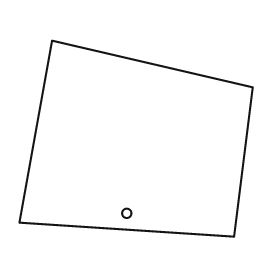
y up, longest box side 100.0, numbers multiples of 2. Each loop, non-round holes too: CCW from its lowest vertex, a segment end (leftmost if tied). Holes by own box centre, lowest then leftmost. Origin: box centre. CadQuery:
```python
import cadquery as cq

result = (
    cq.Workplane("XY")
    .moveTo(42.0, -42.0)
    .lineTo(50.0, 22.0)
    .lineTo(-36.0, 42.0)
    .lineTo(-50.0, -36.0)
    .close()
    .moveTo(-4.0, -32.0)
    .circle(2.0)
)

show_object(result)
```